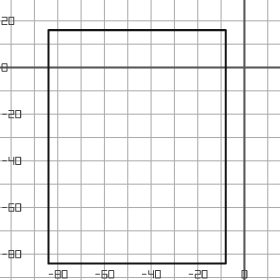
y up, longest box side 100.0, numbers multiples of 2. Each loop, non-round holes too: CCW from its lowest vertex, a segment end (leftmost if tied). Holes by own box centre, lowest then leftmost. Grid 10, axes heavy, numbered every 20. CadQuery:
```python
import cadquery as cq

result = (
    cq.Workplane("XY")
    .moveTo(-84.0, -84.0)
    .lineTo(-8.0, -84.0)
    .lineTo(-8.0, 16.0)
    .lineTo(-84.0, 16.0)
    .close()
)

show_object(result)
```